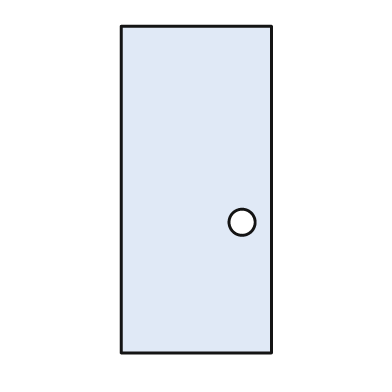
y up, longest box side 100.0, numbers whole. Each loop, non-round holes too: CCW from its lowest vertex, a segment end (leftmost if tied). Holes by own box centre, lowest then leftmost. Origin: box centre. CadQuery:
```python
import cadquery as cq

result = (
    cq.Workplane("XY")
    .moveTo(-23.0, -50.0)
    .lineTo(23.0, -50.0)
    .lineTo(23.0, 50.0)
    .lineTo(-23.0, 50.0)
    .close()
    .moveTo(14.0, -10.0)
    .circle(4.0)
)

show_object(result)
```